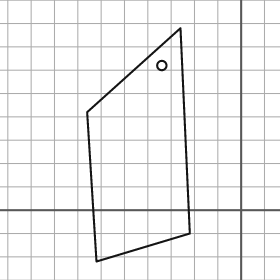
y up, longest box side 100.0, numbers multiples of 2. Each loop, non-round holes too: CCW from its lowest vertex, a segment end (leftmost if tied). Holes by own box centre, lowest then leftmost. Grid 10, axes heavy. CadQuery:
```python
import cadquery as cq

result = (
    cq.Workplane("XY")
    .moveTo(-62.0, -22.0)
    .lineTo(-22.0, -10.0)
    .lineTo(-26.0, 78.0)
    .lineTo(-66.0, 42.0)
    .close()
    .moveTo(-34.0, 62.0)
    .circle(2.0)
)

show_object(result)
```